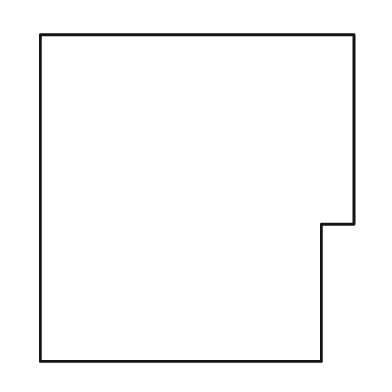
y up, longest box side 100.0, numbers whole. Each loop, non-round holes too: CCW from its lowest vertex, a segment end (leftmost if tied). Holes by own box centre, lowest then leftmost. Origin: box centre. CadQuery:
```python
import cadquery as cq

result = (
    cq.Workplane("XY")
    .moveTo(-48.0, -50.0)
    .lineTo(38.0, -50.0)
    .lineTo(38.0, -8.0)
    .lineTo(48.0, -8.0)
    .lineTo(48.0, 50.0)
    .lineTo(-48.0, 50.0)
    .close()
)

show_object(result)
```